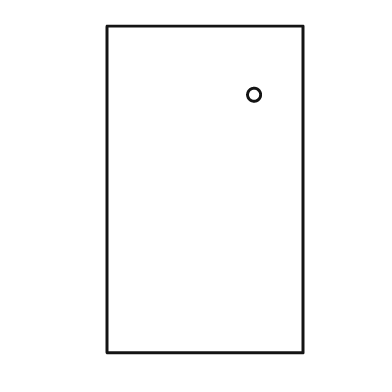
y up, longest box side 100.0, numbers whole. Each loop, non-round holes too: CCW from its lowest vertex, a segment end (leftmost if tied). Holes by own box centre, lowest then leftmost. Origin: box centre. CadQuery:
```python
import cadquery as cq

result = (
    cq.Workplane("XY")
    .moveTo(-30.0, -50.0)
    .lineTo(30.0, -50.0)
    .lineTo(30.0, 50.0)
    .lineTo(-30.0, 50.0)
    .close()
    .moveTo(15.0, 29.0)
    .circle(2.0)
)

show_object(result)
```